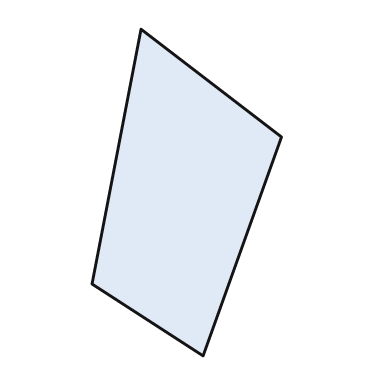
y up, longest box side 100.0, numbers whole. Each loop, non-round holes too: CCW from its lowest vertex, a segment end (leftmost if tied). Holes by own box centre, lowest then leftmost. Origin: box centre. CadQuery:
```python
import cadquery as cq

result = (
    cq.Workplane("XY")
    .moveTo(5.0, -50.0)
    .lineTo(29.0, 17.0)
    .lineTo(-14.0, 50.0)
    .lineTo(-29.0, -28.0)
    .close()
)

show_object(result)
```